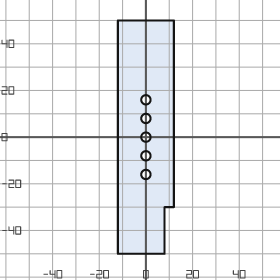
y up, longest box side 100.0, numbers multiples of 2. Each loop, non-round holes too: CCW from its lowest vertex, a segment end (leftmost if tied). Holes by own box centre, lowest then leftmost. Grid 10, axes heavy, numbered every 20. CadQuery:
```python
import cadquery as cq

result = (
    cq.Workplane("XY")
    .moveTo(-12.0, -50.0)
    .lineTo(8.0, -50.0)
    .lineTo(8.0, -30.0)
    .lineTo(12.0, -30.0)
    .lineTo(12.0, 50.0)
    .lineTo(-12.0, 50.0)
    .close()
    .moveTo(0.0, -16.0)
    .circle(2.0)
    .moveTo(0.0, -8.0)
    .circle(2.0)
    .moveTo(0.0, 0.0)
    .circle(2.0)
    .moveTo(0.0, 8.0)
    .circle(2.0)
    .moveTo(0.0, 16.0)
    .circle(2.0)
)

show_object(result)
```